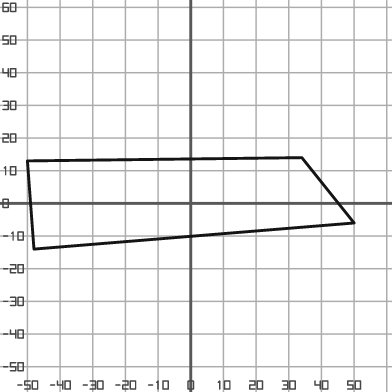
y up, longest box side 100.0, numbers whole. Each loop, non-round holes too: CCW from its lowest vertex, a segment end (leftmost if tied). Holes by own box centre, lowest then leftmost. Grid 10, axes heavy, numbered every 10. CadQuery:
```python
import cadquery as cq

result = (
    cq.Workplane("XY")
    .moveTo(-48.0, -14.0)
    .lineTo(50.0, -6.0)
    .lineTo(34.0, 14.0)
    .lineTo(-50.0, 13.0)
    .close()
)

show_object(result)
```